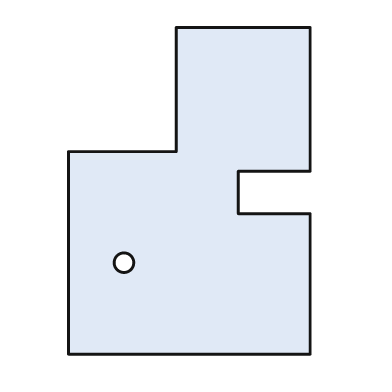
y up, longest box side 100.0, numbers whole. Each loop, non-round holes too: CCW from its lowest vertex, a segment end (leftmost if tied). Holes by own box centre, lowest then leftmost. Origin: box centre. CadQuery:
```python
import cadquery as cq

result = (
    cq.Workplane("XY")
    .moveTo(-37.0, -50.0)
    .lineTo(37.0, -50.0)
    .lineTo(37.0, -7.0)
    .lineTo(15.0, -7.0)
    .lineTo(15.0, 6.0)
    .lineTo(37.0, 6.0)
    .lineTo(37.0, 50.0)
    .lineTo(-4.0, 50.0)
    .lineTo(-4.0, 12.0)
    .lineTo(-37.0, 12.0)
    .close()
    .moveTo(-20.0, -22.0)
    .circle(3.0)
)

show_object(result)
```